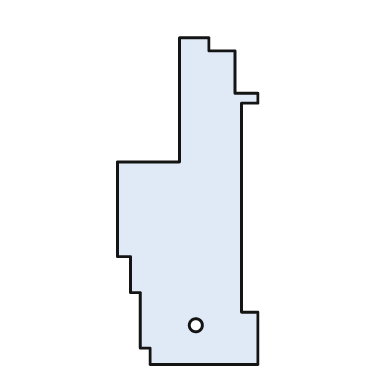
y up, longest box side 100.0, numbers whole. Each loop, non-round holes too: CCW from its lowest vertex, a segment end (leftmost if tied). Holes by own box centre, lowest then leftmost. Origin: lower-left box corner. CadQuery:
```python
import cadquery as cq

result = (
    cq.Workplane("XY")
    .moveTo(10.0, 0.0)
    .lineTo(43.0, 0.0)
    .lineTo(43.0, 16.0)
    .lineTo(38.0, 16.0)
    .lineTo(38.0, 80.0)
    .lineTo(43.0, 80.0)
    .lineTo(43.0, 83.0)
    .lineTo(36.0, 83.0)
    .lineTo(36.0, 96.0)
    .lineTo(28.0, 96.0)
    .lineTo(28.0, 100.0)
    .lineTo(19.0, 100.0)
    .lineTo(19.0, 62.0)
    .lineTo(0.0, 62.0)
    .lineTo(0.0, 33.0)
    .lineTo(4.0, 33.0)
    .lineTo(4.0, 22.0)
    .lineTo(7.0, 22.0)
    .lineTo(7.0, 5.0)
    .lineTo(10.0, 5.0)
    .close()
    .moveTo(24.0, 12.0)
    .circle(2.0)
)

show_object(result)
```